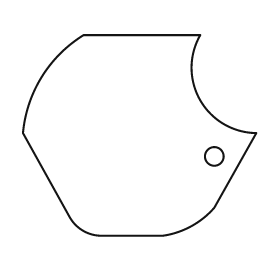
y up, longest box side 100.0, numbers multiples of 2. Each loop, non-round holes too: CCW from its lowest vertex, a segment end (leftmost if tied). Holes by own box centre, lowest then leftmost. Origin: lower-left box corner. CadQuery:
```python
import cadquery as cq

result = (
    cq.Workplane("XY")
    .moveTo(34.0, 0.0)
    .lineTo(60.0, 0.0)
    .threePointArc((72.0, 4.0), (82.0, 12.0))
    .lineTo(100.0, 44.0)
    .threePointArc((76.0, 58.0), (76.0, 86.0))
    .lineTo(26.0, 86.0)
    .threePointArc((8.0, 68.0), (0.0, 44.0))
    .lineTo(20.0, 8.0)
    .threePointArc((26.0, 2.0), (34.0, 0.0))
    .close()
    .moveTo(82.0, 34.0)
    .circle(4.0)
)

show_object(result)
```